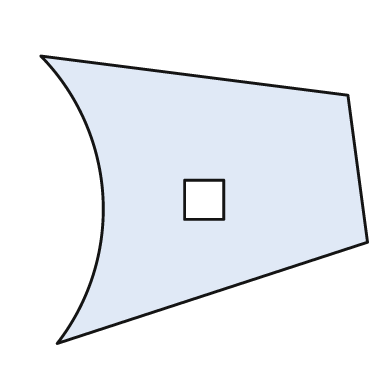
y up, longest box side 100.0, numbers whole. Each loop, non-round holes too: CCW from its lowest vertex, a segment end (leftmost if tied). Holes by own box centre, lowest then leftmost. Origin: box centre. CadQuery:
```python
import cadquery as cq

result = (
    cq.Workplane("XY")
    .moveTo(-45.0, -44.0)
    .lineTo(50.0, -13.0)
    .lineTo(44.0, 32.0)
    .lineTo(-50.0, 44.0)
    .threePointArc((-31.0, 1.0), (-45.0, -44.0))
    .close()
    .moveTo(-6.0, -6.0)
    .lineTo(6.0, -6.0)
    .lineTo(6.0, 6.0)
    .lineTo(-6.0, 6.0)
    .close()
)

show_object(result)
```